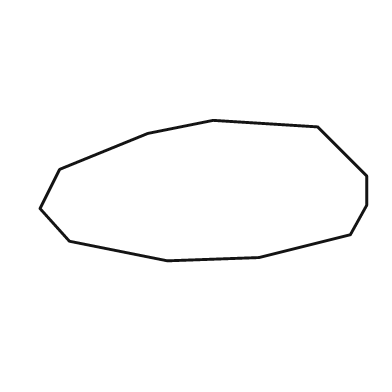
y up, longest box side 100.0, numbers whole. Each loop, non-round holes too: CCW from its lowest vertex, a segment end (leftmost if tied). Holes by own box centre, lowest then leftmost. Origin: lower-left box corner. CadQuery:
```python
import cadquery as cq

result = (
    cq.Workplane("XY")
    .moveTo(39.0, 0.0)
    .lineTo(67.0, 1.0)
    .lineTo(95.0, 8.0)
    .lineTo(100.0, 17.0)
    .lineTo(100.0, 26.0)
    .lineTo(85.0, 41.0)
    .lineTo(53.0, 43.0)
    .lineTo(33.0, 39.0)
    .lineTo(6.0, 28.0)
    .lineTo(0.0, 16.0)
    .lineTo(9.0, 6.0)
    .close()
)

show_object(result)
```